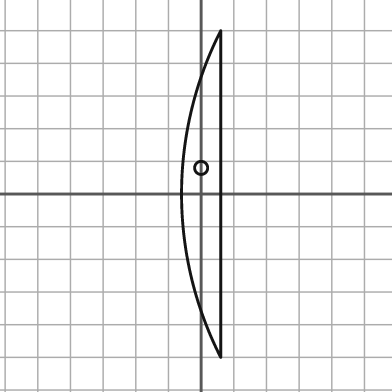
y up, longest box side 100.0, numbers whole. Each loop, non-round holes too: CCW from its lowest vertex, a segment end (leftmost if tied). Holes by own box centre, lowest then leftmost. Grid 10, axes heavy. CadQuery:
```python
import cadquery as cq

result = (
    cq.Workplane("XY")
    .moveTo(6.0, -50.0)
    .lineTo(6.0, 50.0)
    .threePointArc((-6.0, 0.0), (6.0, -50.0))
    .close()
    .moveTo(0.0, 8.0)
    .circle(2.0)
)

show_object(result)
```